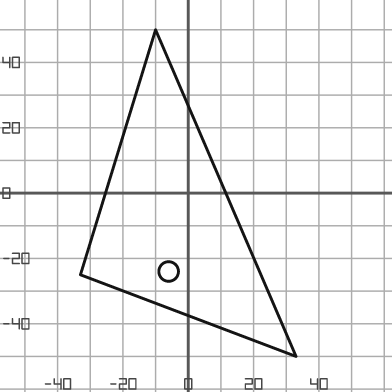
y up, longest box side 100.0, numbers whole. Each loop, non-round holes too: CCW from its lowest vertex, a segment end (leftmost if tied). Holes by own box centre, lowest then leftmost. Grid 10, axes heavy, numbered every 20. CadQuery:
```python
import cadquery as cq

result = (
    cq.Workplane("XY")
    .moveTo(33.0, -50.0)
    .lineTo(-10.0, 50.0)
    .lineTo(-33.0, -25.0)
    .close()
    .moveTo(-6.0, -24.0)
    .circle(3.0)
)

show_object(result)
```